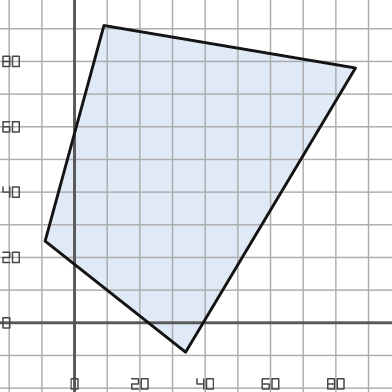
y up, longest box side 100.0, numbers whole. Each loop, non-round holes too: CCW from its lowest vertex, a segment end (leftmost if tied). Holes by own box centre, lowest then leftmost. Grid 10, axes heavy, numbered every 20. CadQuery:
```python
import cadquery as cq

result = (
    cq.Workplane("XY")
    .moveTo(34.0, -9.0)
    .lineTo(86.0, 78.0)
    .lineTo(9.0, 91.0)
    .lineTo(-9.0, 25.0)
    .close()
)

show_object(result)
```